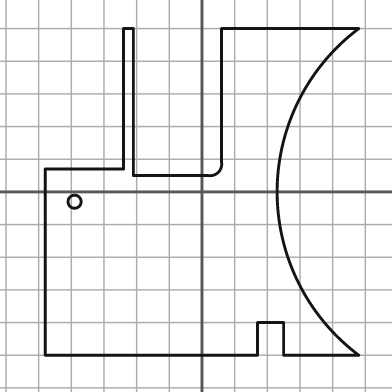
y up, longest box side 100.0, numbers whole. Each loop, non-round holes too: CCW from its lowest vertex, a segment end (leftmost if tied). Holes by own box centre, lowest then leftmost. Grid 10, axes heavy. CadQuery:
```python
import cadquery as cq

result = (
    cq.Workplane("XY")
    .moveTo(-48.0, -50.0)
    .lineTo(17.0, -50.0)
    .lineTo(17.0, -40.0)
    .lineTo(25.0, -40.0)
    .lineTo(25.0, -50.0)
    .lineTo(48.0, -50.0)
    .threePointArc((23.0, 0.0), (48.0, 50.0))
    .lineTo(6.0, 50.0)
    .lineTo(6.0, 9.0)
    .threePointArc((5.0, 6.0), (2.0, 5.0))
    .lineTo(-21.0, 5.0)
    .lineTo(-21.0, 50.0)
    .lineTo(-24.0, 50.0)
    .lineTo(-24.0, 7.0)
    .lineTo(-48.0, 7.0)
    .close()
    .moveTo(-39.0, -3.0)
    .circle(2.0)
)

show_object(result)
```